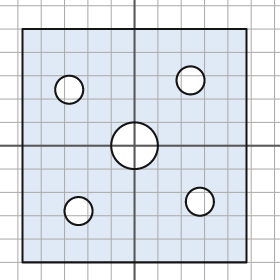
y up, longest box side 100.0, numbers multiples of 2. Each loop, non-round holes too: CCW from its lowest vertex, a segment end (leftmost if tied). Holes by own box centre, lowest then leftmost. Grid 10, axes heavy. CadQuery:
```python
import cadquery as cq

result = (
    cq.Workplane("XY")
    .moveTo(-48.0, -50.0)
    .lineTo(48.0, -50.0)
    .lineTo(48.0, 50.0)
    .lineTo(-48.0, 50.0)
    .close()
    .moveTo(-24.0, -28.0)
    .circle(6.0)
    .moveTo(28.0, -24.0)
    .circle(6.0)
    .moveTo(0.0, 0.0)
    .circle(10.0)
    .moveTo(-28.0, 24.0)
    .circle(6.0)
    .moveTo(24.0, 28.0)
    .circle(6.0)
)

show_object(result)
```